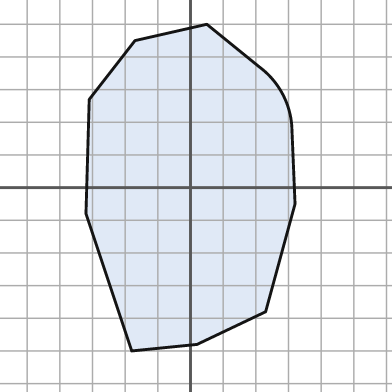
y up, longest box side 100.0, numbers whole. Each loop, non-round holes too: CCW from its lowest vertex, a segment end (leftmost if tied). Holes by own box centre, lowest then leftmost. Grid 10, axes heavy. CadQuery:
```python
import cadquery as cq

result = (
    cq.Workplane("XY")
    .moveTo(-18.0, -50.0)
    .lineTo(2.0, -48.0)
    .lineTo(23.0, -38.0)
    .lineTo(32.0, -5.0)
    .lineTo(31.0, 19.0)
    .threePointArc((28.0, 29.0), (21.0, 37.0))
    .lineTo(5.0, 50.0)
    .lineTo(-17.0, 45.0)
    .lineTo(-31.0, 27.0)
    .lineTo(-32.0, -8.0)
    .close()
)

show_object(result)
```